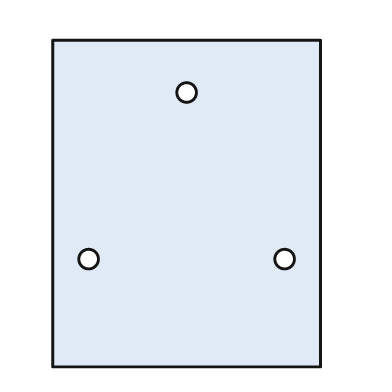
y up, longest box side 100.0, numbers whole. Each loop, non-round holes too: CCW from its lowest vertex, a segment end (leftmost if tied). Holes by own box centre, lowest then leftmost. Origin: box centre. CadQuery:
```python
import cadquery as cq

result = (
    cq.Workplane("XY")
    .moveTo(-41.0, -50.0)
    .lineTo(41.0, -50.0)
    .lineTo(41.0, 50.0)
    .lineTo(-41.0, 50.0)
    .close()
    .moveTo(-30.0, -17.0)
    .circle(3.0)
    .moveTo(30.0, -17.0)
    .circle(3.0)
    .moveTo(0.0, 34.0)
    .circle(3.0)
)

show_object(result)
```